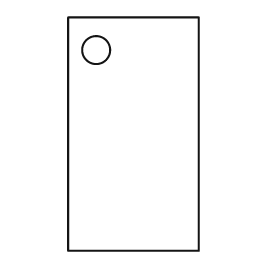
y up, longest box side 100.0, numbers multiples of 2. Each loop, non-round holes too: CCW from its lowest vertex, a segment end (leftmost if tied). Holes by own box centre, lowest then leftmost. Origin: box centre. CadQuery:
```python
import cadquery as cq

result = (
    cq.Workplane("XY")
    .moveTo(-28.0, -50.0)
    .lineTo(28.0, -50.0)
    .lineTo(28.0, 50.0)
    .lineTo(-28.0, 50.0)
    .close()
    .moveTo(-16.0, 36.0)
    .circle(6.0)
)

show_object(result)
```